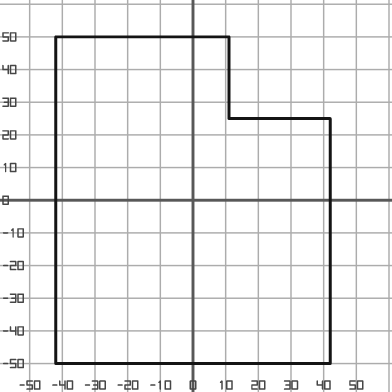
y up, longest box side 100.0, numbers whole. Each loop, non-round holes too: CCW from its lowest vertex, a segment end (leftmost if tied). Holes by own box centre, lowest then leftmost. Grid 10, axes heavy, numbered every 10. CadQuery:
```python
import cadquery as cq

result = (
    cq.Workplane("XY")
    .moveTo(-42.0, -50.0)
    .lineTo(42.0, -50.0)
    .lineTo(42.0, 25.0)
    .lineTo(11.0, 25.0)
    .lineTo(11.0, 50.0)
    .lineTo(-42.0, 50.0)
    .close()
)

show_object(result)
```